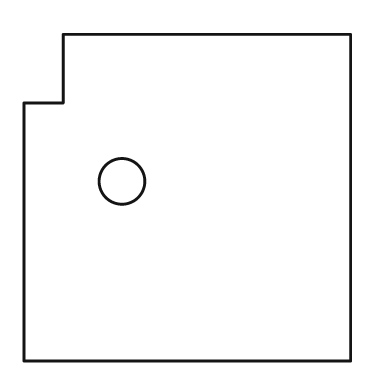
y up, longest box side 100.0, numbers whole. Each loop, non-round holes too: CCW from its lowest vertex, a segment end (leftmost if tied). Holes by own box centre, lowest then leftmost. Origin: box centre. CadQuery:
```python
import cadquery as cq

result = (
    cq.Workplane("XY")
    .moveTo(-50.0, -50.0)
    .lineTo(50.0, -50.0)
    .lineTo(50.0, 50.0)
    .lineTo(-38.0, 50.0)
    .lineTo(-38.0, 29.0)
    .lineTo(-50.0, 29.0)
    .close()
    .moveTo(-20.0, 5.0)
    .circle(7.0)
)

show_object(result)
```